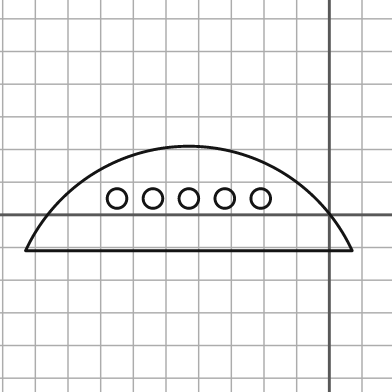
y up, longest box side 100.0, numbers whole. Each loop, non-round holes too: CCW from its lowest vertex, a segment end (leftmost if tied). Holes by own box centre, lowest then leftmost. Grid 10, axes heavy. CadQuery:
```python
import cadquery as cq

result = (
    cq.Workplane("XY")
    .moveTo(-93.0, -11.0)
    .lineTo(7.0, -11.0)
    .threePointArc((-43.0, 21.0), (-93.0, -11.0))
    .close()
    .moveTo(-65.0, 5.0)
    .circle(3.0)
    .moveTo(-54.0, 5.0)
    .circle(3.0)
    .moveTo(-43.0, 5.0)
    .circle(3.0)
    .moveTo(-32.0, 5.0)
    .circle(3.0)
    .moveTo(-21.0, 5.0)
    .circle(3.0)
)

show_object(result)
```